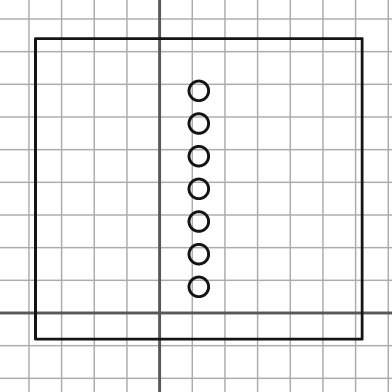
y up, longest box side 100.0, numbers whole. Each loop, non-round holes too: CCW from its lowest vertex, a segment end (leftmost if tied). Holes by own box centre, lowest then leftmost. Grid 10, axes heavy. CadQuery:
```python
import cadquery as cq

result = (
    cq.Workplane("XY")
    .moveTo(-38.0, -8.0)
    .lineTo(62.0, -8.0)
    .lineTo(62.0, 84.0)
    .lineTo(-38.0, 84.0)
    .close()
    .moveTo(12.0, 8.0)
    .circle(3.0)
    .moveTo(12.0, 18.0)
    .circle(3.0)
    .moveTo(12.0, 28.0)
    .circle(3.0)
    .moveTo(12.0, 38.0)
    .circle(3.0)
    .moveTo(12.0, 48.0)
    .circle(3.0)
    .moveTo(12.0, 58.0)
    .circle(3.0)
    .moveTo(12.0, 68.0)
    .circle(3.0)
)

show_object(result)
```